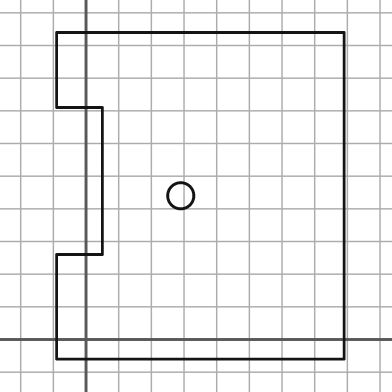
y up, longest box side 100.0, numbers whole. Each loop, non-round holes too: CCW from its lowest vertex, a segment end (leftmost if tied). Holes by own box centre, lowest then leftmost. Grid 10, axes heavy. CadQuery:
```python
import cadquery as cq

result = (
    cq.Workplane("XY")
    .moveTo(-9.0, -6.0)
    .lineTo(79.0, -6.0)
    .lineTo(79.0, 94.0)
    .lineTo(-9.0, 94.0)
    .lineTo(-9.0, 71.0)
    .lineTo(5.0, 71.0)
    .lineTo(5.0, 26.0)
    .lineTo(-9.0, 26.0)
    .close()
    .moveTo(29.0, 44.0)
    .circle(4.0)
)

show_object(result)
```